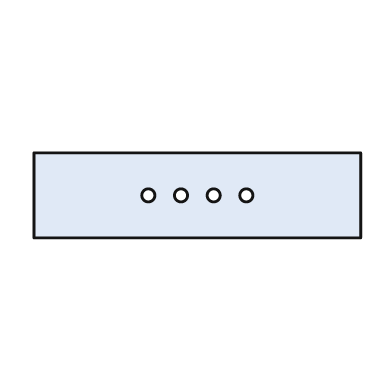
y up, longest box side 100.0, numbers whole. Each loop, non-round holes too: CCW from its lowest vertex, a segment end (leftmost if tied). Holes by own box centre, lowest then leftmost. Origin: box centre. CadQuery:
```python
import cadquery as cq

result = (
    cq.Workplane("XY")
    .moveTo(-50.0, -13.0)
    .lineTo(50.0, -13.0)
    .lineTo(50.0, 13.0)
    .lineTo(-50.0, 13.0)
    .close()
    .moveTo(-15.0, 0.0)
    .circle(2.0)
    .moveTo(-5.0, 0.0)
    .circle(2.0)
    .moveTo(5.0, 0.0)
    .circle(2.0)
    .moveTo(15.0, 0.0)
    .circle(2.0)
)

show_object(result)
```